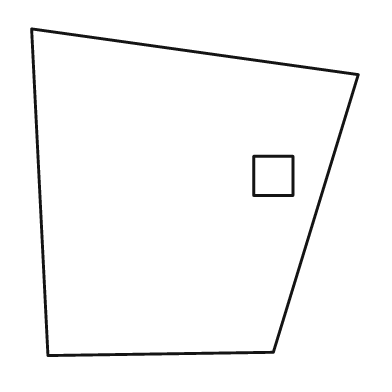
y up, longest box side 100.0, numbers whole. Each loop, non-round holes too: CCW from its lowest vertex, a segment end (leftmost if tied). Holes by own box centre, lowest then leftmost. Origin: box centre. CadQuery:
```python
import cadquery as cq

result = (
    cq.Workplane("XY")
    .moveTo(-45.0, -50.0)
    .lineTo(24.0, -49.0)
    .lineTo(50.0, 36.0)
    .lineTo(-50.0, 50.0)
    .close()
    .moveTo(18.0, -1.0)
    .lineTo(30.0, -1.0)
    .lineTo(30.0, 11.0)
    .lineTo(18.0, 11.0)
    .close()
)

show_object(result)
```